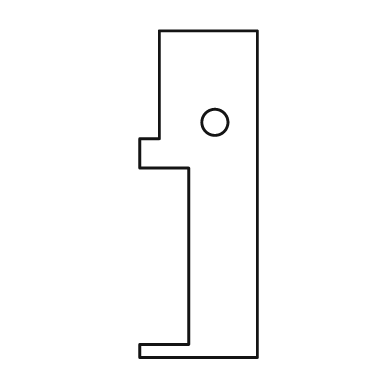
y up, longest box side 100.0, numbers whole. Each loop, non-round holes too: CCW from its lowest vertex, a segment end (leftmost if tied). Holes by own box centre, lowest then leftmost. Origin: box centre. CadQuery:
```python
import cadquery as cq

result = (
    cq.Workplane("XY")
    .moveTo(-18.0, -50.0)
    .lineTo(18.0, -50.0)
    .lineTo(18.0, 50.0)
    .lineTo(-12.0, 50.0)
    .lineTo(-12.0, 17.0)
    .lineTo(-18.0, 17.0)
    .lineTo(-18.0, 8.0)
    .lineTo(-3.0, 8.0)
    .lineTo(-3.0, -46.0)
    .lineTo(-18.0, -46.0)
    .close()
    .moveTo(5.0, 22.0)
    .circle(4.0)
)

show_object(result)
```